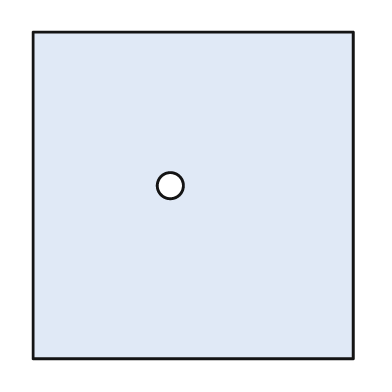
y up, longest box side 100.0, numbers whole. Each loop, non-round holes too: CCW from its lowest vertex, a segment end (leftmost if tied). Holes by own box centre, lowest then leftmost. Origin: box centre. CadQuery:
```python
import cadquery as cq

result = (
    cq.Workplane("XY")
    .moveTo(-49.0, -50.0)
    .lineTo(49.0, -50.0)
    .lineTo(49.0, 50.0)
    .lineTo(-49.0, 50.0)
    .close()
    .moveTo(-7.0, 3.0)
    .circle(4.0)
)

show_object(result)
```